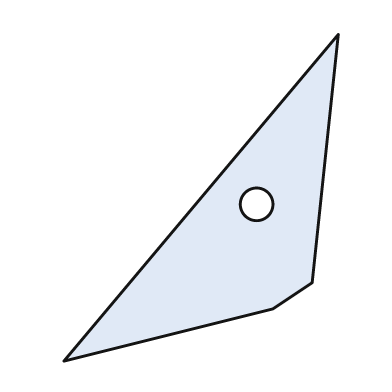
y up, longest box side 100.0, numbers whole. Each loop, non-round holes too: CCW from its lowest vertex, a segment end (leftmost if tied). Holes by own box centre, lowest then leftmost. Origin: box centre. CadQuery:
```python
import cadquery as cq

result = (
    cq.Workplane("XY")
    .moveTo(-42.0, -50.0)
    .lineTo(22.0, -34.0)
    .lineTo(34.0, -26.0)
    .lineTo(42.0, 50.0)
    .close()
    .moveTo(17.0, -2.0)
    .circle(5.0)
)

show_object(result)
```